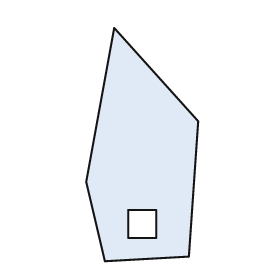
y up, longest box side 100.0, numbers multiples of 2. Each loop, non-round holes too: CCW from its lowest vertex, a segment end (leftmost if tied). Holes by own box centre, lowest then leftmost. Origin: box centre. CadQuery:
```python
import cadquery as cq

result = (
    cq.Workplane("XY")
    .moveTo(-16.0, -50.0)
    .lineTo(20.0, -48.0)
    .lineTo(24.0, 10.0)
    .lineTo(-12.0, 50.0)
    .lineTo(-24.0, -16.0)
    .close()
    .moveTo(-6.0, -40.0)
    .lineTo(6.0, -40.0)
    .lineTo(6.0, -28.0)
    .lineTo(-6.0, -28.0)
    .close()
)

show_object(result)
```